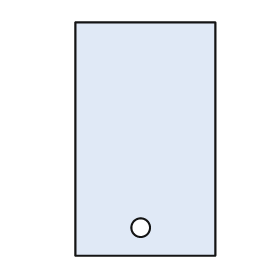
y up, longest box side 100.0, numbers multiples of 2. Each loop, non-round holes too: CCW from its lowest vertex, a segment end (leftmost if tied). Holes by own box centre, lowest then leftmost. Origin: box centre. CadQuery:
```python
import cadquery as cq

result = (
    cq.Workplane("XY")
    .moveTo(-30.0, -50.0)
    .lineTo(30.0, -50.0)
    .lineTo(30.0, 50.0)
    .lineTo(-30.0, 50.0)
    .close()
    .moveTo(-2.0, -38.0)
    .circle(4.0)
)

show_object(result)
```